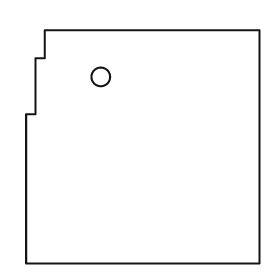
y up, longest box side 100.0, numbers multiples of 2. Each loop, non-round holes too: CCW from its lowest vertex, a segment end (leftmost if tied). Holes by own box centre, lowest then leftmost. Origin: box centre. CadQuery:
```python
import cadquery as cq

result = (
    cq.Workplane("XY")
    .moveTo(-50.0, -50.0)
    .lineTo(50.0, -50.0)
    .lineTo(50.0, 50.0)
    .lineTo(-42.0, 50.0)
    .lineTo(-42.0, 38.0)
    .lineTo(-46.0, 38.0)
    .lineTo(-46.0, 14.0)
    .lineTo(-50.0, 14.0)
    .close()
    .moveTo(-18.0, 30.0)
    .circle(4.0)
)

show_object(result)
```